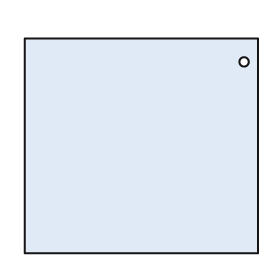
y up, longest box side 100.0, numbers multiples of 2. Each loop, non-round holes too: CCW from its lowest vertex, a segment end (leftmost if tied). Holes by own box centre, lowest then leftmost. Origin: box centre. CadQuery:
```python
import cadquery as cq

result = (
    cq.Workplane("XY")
    .moveTo(-50.0, -46.0)
    .lineTo(50.0, -46.0)
    .lineTo(50.0, 46.0)
    .lineTo(-50.0, 46.0)
    .close()
    .moveTo(44.0, 36.0)
    .circle(2.0)
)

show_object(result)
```